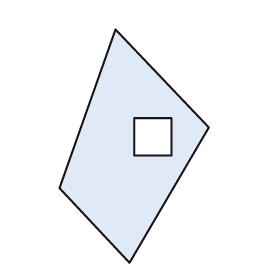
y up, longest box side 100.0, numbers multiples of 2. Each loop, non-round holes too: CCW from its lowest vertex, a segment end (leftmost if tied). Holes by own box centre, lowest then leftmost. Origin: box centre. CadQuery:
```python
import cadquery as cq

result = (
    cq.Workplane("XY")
    .moveTo(-2.0, -50.0)
    .lineTo(32.0, 8.0)
    .lineTo(-8.0, 50.0)
    .lineTo(-32.0, -18.0)
    .close()
    .moveTo(0.0, -4.0)
    .lineTo(16.0, -4.0)
    .lineTo(16.0, 12.0)
    .lineTo(0.0, 12.0)
    .close()
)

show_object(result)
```